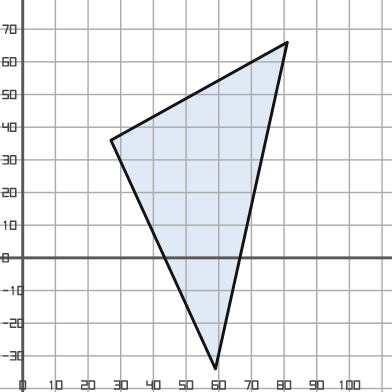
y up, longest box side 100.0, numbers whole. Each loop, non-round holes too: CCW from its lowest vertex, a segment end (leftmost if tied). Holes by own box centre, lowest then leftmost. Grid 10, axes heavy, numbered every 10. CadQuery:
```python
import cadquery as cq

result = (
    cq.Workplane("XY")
    .moveTo(59.0, -34.0)
    .lineTo(81.0, 66.0)
    .lineTo(27.0, 36.0)
    .close()
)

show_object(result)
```